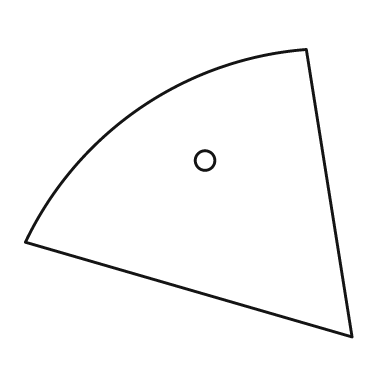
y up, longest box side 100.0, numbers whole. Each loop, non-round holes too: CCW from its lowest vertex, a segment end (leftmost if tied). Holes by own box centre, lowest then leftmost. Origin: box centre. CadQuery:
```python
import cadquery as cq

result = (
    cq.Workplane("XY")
    .moveTo(50.0, -44.0)
    .lineTo(36.0, 44.0)
    .threePointArc((-15.0, 26.0), (-50.0, -15.0))
    .close()
    .moveTo(5.0, 10.0)
    .circle(3.0)
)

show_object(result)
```